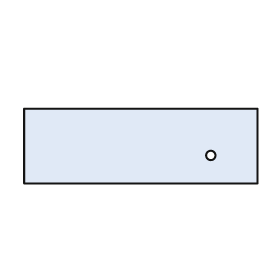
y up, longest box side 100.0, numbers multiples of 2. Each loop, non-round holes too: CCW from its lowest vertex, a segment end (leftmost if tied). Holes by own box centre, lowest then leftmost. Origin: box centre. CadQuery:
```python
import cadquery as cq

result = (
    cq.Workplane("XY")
    .moveTo(-50.0, -16.0)
    .lineTo(50.0, -16.0)
    .lineTo(50.0, 16.0)
    .lineTo(-50.0, 16.0)
    .close()
    .moveTo(30.0, -4.0)
    .circle(2.0)
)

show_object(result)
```